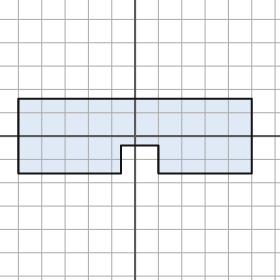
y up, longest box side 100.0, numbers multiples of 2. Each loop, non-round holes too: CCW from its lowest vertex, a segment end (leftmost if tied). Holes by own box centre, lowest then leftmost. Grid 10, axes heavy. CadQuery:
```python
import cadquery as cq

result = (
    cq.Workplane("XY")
    .moveTo(-50.0, -16.0)
    .lineTo(-6.0, -16.0)
    .lineTo(-6.0, -4.0)
    .lineTo(10.0, -4.0)
    .lineTo(10.0, -16.0)
    .lineTo(50.0, -16.0)
    .lineTo(50.0, 16.0)
    .lineTo(-50.0, 16.0)
    .close()
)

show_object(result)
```